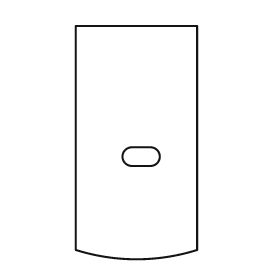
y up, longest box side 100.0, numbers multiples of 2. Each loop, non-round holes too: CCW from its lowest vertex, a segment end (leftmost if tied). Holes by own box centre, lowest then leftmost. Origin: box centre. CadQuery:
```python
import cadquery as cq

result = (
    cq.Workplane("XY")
    .moveTo(-26.0, -46.0)
    .threePointArc((0.0, -50.0), (26.0, -46.0))
    .lineTo(26.0, 50.0)
    .lineTo(-26.0, 50.0)
    .close()
    .moveTo(-2.0, -10.0)
    .lineTo(6.0, -10.0)
    .threePointArc((10.0, -6.0), (6.0, -2.0))
    .lineTo(-2.0, -2.0)
    .threePointArc((-6.0, -6.0), (-2.0, -10.0))
    .close()
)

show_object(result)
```